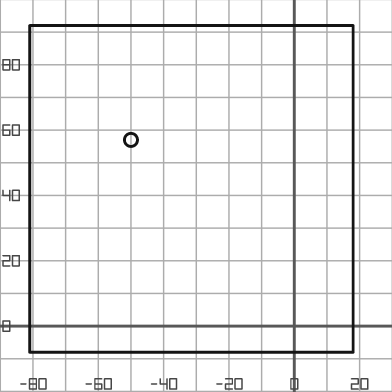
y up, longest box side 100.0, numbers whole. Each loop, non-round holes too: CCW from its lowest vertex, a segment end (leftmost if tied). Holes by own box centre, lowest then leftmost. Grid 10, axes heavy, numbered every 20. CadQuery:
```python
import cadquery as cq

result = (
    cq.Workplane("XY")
    .moveTo(-81.0, -8.0)
    .lineTo(18.0, -8.0)
    .lineTo(18.0, 92.0)
    .lineTo(-81.0, 92.0)
    .close()
    .moveTo(-50.0, 57.0)
    .circle(2.0)
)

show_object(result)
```